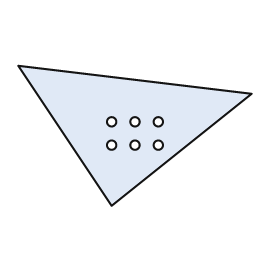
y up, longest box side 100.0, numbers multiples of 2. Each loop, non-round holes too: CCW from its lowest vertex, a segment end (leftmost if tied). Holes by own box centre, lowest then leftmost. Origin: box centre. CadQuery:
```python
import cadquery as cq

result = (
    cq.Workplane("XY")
    .moveTo(-10.0, -30.0)
    .lineTo(50.0, 18.0)
    .lineTo(-50.0, 30.0)
    .close()
    .moveTo(-10.0, -4.0)
    .circle(2.0)
    .moveTo(0.0, -4.0)
    .circle(2.0)
    .moveTo(10.0, -4.0)
    .circle(2.0)
    .moveTo(-10.0, 6.0)
    .circle(2.0)
    .moveTo(0.0, 6.0)
    .circle(2.0)
    .moveTo(10.0, 6.0)
    .circle(2.0)
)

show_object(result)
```